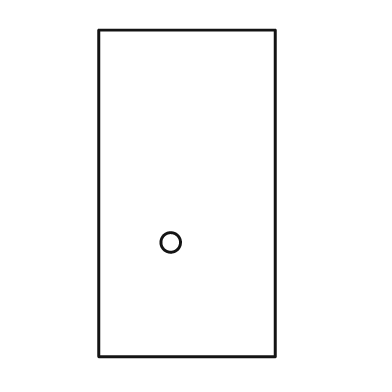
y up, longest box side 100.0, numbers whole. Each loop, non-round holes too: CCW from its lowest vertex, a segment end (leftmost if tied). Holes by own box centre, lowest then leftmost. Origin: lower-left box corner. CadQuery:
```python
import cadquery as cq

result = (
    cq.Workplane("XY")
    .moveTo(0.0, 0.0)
    .lineTo(54.0, 0.0)
    .lineTo(54.0, 100.0)
    .lineTo(0.0, 100.0)
    .close()
    .moveTo(22.0, 35.0)
    .circle(3.0)
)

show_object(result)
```